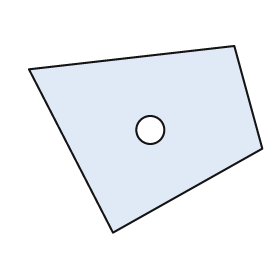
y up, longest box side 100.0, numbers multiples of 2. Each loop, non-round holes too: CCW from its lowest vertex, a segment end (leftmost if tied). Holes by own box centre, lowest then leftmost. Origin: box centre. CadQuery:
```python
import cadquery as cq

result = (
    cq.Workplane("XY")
    .moveTo(-14.0, -40.0)
    .lineTo(50.0, -4.0)
    .lineTo(38.0, 40.0)
    .lineTo(-50.0, 30.0)
    .close()
    .moveTo(2.0, 4.0)
    .circle(6.0)
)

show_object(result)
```